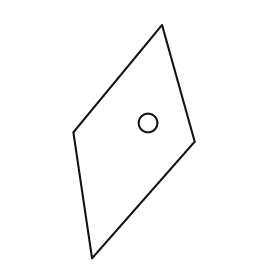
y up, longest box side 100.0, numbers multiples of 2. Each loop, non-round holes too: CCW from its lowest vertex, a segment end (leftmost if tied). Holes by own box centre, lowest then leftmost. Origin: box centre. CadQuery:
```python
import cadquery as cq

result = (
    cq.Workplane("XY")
    .moveTo(-18.0, -50.0)
    .lineTo(26.0, 0.0)
    .lineTo(12.0, 50.0)
    .lineTo(-26.0, 4.0)
    .close()
    .moveTo(6.0, 8.0)
    .circle(4.0)
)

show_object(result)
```